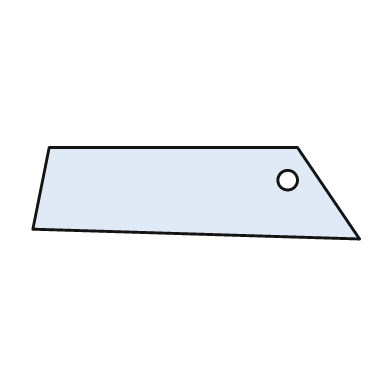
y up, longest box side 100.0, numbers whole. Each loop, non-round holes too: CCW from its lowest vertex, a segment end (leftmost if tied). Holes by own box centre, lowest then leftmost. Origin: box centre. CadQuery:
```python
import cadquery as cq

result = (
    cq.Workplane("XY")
    .moveTo(50.0, -14.0)
    .lineTo(31.0, 14.0)
    .lineTo(-45.0, 14.0)
    .lineTo(-50.0, -11.0)
    .close()
    .moveTo(28.0, 4.0)
    .circle(3.0)
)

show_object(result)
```